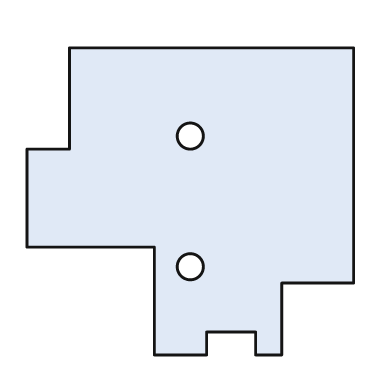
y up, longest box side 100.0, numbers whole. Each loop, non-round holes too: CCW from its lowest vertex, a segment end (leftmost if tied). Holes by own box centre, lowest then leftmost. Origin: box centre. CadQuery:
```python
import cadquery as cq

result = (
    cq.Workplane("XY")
    .moveTo(-11.0, -47.0)
    .lineTo(5.0, -47.0)
    .lineTo(5.0, -40.0)
    .lineTo(20.0, -40.0)
    .lineTo(20.0, -47.0)
    .lineTo(28.0, -47.0)
    .lineTo(28.0, -25.0)
    .lineTo(50.0, -25.0)
    .lineTo(50.0, 47.0)
    .lineTo(-37.0, 47.0)
    .lineTo(-37.0, 16.0)
    .lineTo(-50.0, 16.0)
    .lineTo(-50.0, -14.0)
    .lineTo(-11.0, -14.0)
    .close()
    .moveTo(0.0, -20.0)
    .circle(4.0)
    .moveTo(0.0, 20.0)
    .circle(4.0)
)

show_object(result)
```